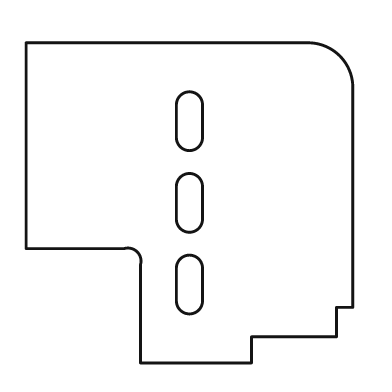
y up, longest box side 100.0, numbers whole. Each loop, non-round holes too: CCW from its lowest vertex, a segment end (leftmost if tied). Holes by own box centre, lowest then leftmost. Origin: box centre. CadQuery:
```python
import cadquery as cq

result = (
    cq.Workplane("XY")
    .moveTo(-15.0, -49.0)
    .lineTo(19.0, -49.0)
    .lineTo(19.0, -41.0)
    .lineTo(45.0, -41.0)
    .lineTo(45.0, -32.0)
    .lineTo(50.0, -32.0)
    .lineTo(50.0, 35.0)
    .threePointArc((46.0, 45.0), (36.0, 49.0))
    .lineTo(-50.0, 49.0)
    .lineTo(-50.0, -14.0)
    .lineTo(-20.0, -14.0)
    .threePointArc((-16.0, -15.0), (-15.0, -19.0))
    .close()
    .moveTo(-4.0, -30.0)
    .threePointArc((0.0, -34.0), (4.0, -30.0))
    .lineTo(4.0, -20.0)
    .threePointArc((0.0, -16.0), (-4.0, -20.0))
    .close()
    .moveTo(-4.0, -5.0)
    .threePointArc((0.0, -9.0), (4.0, -5.0))
    .lineTo(4.0, 5.0)
    .threePointArc((0.0, 9.0), (-4.0, 5.0))
    .close()
    .moveTo(-4.0, 20.0)
    .threePointArc((0.0, 16.0), (4.0, 20.0))
    .lineTo(4.0, 30.0)
    .threePointArc((0.0, 34.0), (-4.0, 30.0))
    .close()
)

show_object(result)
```